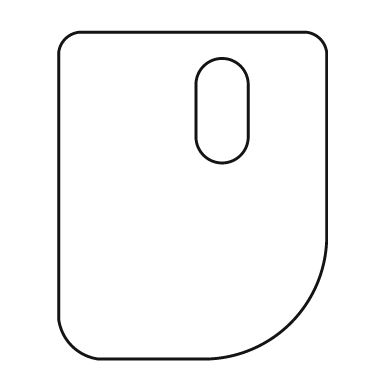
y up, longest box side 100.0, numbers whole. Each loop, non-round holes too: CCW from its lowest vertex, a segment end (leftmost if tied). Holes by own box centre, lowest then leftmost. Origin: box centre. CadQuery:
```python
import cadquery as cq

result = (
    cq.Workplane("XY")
    .moveTo(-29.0, -50.0)
    .lineTo(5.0, -50.0)
    .threePointArc((30.0, -39.0), (41.0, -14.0))
    .lineTo(41.0, 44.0)
    .threePointArc((39.0, 48.0), (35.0, 50.0))
    .lineTo(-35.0, 50.0)
    .threePointArc((-39.0, 48.0), (-41.0, 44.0))
    .lineTo(-41.0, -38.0)
    .threePointArc((-37.0, -46.0), (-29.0, -50.0))
    .close()
    .moveTo(1.0, 18.0)
    .threePointArc((9.0, 10.0), (17.0, 18.0))
    .lineTo(17.0, 34.0)
    .threePointArc((9.0, 42.0), (1.0, 34.0))
    .close()
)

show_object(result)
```